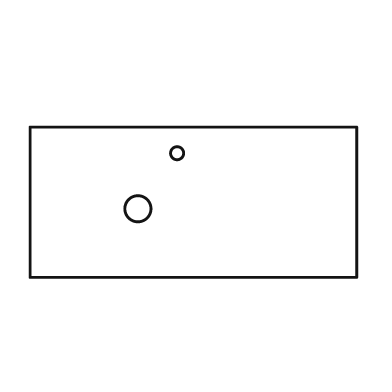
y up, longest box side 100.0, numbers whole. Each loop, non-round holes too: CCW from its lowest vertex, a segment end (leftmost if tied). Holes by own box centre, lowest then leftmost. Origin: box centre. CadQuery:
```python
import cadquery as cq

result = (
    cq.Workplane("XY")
    .moveTo(-50.0, -23.0)
    .lineTo(50.0, -23.0)
    .lineTo(50.0, 23.0)
    .lineTo(-50.0, 23.0)
    .close()
    .moveTo(-17.0, -2.0)
    .circle(4.0)
    .moveTo(-5.0, 15.0)
    .circle(2.0)
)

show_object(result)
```